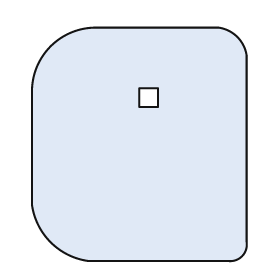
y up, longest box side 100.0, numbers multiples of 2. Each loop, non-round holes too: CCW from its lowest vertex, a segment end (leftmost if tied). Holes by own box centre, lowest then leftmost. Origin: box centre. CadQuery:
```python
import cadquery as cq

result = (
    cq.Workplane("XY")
    .moveTo(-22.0, -50.0)
    .lineTo(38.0, -50.0)
    .threePointArc((44.0, -48.0), (46.0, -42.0))
    .lineTo(46.0, 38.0)
    .threePointArc((42.0, 46.0), (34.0, 50.0))
    .lineTo(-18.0, 50.0)
    .threePointArc((-38.0, 42.0), (-46.0, 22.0))
    .lineTo(-46.0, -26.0)
    .threePointArc((-38.0, -42.0), (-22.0, -50.0))
    .close()
    .moveTo(0.0, 16.0)
    .lineTo(8.0, 16.0)
    .lineTo(8.0, 24.0)
    .lineTo(0.0, 24.0)
    .close()
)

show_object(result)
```